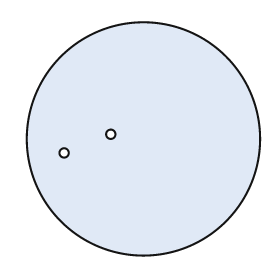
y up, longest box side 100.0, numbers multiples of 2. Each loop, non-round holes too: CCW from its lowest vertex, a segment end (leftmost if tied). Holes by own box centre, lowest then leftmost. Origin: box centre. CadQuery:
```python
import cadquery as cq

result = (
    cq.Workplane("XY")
    .moveTo(0.0, 0.0)
    .circle(50.0)
    .moveTo(-34.0, -6.0)
    .circle(2.0)
    .moveTo(-14.0, 2.0)
    .circle(2.0)
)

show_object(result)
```